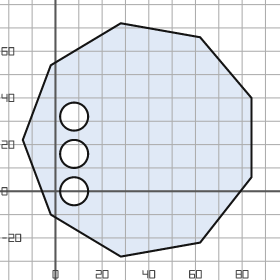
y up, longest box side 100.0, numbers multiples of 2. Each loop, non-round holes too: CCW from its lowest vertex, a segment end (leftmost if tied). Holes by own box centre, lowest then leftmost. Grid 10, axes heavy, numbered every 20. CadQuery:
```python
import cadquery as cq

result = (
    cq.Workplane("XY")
    .moveTo(28.0, -28.0)
    .lineTo(62.0, -22.0)
    .lineTo(84.0, 6.0)
    .lineTo(84.0, 40.0)
    .lineTo(62.0, 66.0)
    .lineTo(28.0, 72.0)
    .lineTo(-2.0, 54.0)
    .lineTo(-14.0, 22.0)
    .lineTo(-2.0, -10.0)
    .close()
    .moveTo(8.0, 0.0)
    .circle(6.0)
    .moveTo(8.0, 16.0)
    .circle(6.0)
    .moveTo(8.0, 32.0)
    .circle(6.0)
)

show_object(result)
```